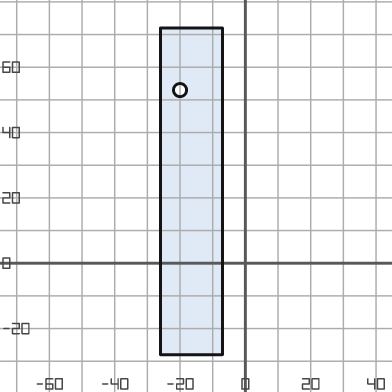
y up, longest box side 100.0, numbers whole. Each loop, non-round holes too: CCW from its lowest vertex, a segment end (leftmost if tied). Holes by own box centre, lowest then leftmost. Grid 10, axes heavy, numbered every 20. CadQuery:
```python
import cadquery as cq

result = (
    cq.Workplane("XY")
    .moveTo(-26.0, -28.0)
    .lineTo(-7.0, -28.0)
    .lineTo(-7.0, 72.0)
    .lineTo(-26.0, 72.0)
    .close()
    .moveTo(-20.0, 53.0)
    .circle(2.0)
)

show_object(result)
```